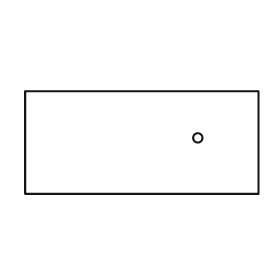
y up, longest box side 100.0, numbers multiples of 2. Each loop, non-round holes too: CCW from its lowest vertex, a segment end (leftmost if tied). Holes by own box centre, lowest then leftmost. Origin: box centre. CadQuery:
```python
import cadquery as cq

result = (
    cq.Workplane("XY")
    .moveTo(-50.0, -22.0)
    .lineTo(50.0, -22.0)
    .lineTo(50.0, 22.0)
    .lineTo(-50.0, 22.0)
    .close()
    .moveTo(24.0, 2.0)
    .circle(2.0)
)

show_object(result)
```